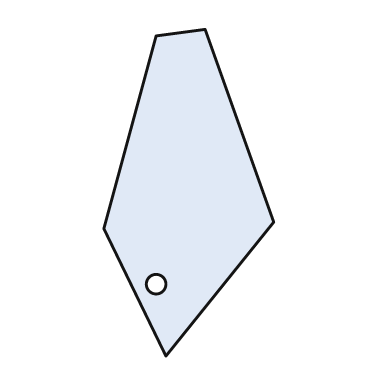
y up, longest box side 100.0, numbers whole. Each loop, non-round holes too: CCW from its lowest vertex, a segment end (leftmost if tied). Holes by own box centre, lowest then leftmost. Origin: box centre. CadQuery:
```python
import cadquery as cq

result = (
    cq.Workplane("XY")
    .moveTo(-7.0, -50.0)
    .lineTo(26.0, -9.0)
    .lineTo(5.0, 50.0)
    .lineTo(-10.0, 48.0)
    .lineTo(-26.0, -11.0)
    .close()
    .moveTo(-10.0, -28.0)
    .circle(3.0)
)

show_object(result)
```